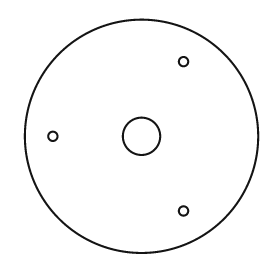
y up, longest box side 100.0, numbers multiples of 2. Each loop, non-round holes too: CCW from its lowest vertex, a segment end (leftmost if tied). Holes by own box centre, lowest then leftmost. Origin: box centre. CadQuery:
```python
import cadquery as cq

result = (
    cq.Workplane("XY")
    .moveTo(0.0, 0.0)
    .circle(50.0)
    .moveTo(18.0, -32.0)
    .circle(2.0)
    .moveTo(-38.0, 0.0)
    .circle(2.0)
    .moveTo(0.0, 0.0)
    .circle(8.0)
    .moveTo(18.0, 32.0)
    .circle(2.0)
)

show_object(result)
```